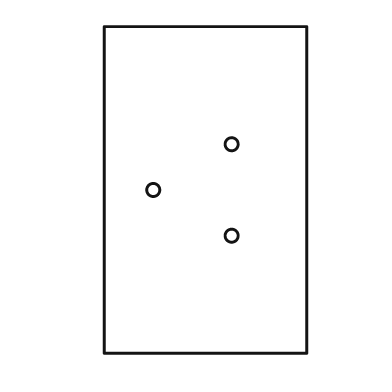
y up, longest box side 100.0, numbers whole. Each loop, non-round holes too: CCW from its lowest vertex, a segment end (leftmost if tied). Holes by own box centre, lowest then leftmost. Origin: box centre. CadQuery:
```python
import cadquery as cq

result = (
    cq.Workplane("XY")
    .moveTo(-31.0, -50.0)
    .lineTo(31.0, -50.0)
    .lineTo(31.0, 50.0)
    .lineTo(-31.0, 50.0)
    .close()
    .moveTo(8.0, -14.0)
    .circle(2.0)
    .moveTo(-16.0, 0.0)
    .circle(2.0)
    .moveTo(8.0, 14.0)
    .circle(2.0)
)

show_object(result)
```